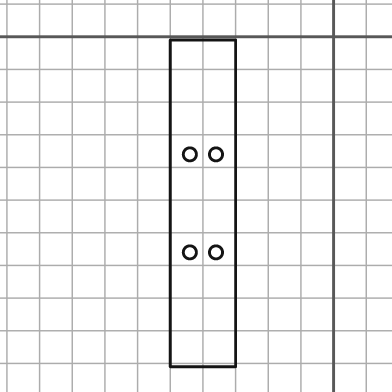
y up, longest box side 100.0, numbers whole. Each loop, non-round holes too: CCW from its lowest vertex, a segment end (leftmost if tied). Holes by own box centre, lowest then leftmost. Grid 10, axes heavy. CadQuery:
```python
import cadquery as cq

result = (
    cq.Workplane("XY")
    .moveTo(-50.0, -101.0)
    .lineTo(-30.0, -101.0)
    .lineTo(-30.0, -1.0)
    .lineTo(-50.0, -1.0)
    .close()
    .moveTo(-44.0, -66.0)
    .circle(2.0)
    .moveTo(-36.0, -66.0)
    .circle(2.0)
    .moveTo(-44.0, -36.0)
    .circle(2.0)
    .moveTo(-36.0, -36.0)
    .circle(2.0)
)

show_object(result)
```